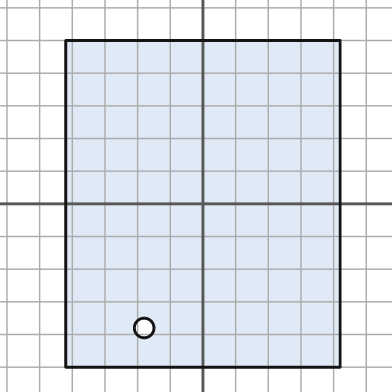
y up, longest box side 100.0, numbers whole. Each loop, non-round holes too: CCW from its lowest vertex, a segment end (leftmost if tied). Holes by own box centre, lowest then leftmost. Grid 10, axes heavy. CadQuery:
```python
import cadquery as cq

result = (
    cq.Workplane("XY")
    .moveTo(-42.0, -50.0)
    .lineTo(42.0, -50.0)
    .lineTo(42.0, 50.0)
    .lineTo(-42.0, 50.0)
    .close()
    .moveTo(-18.0, -38.0)
    .circle(3.0)
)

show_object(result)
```